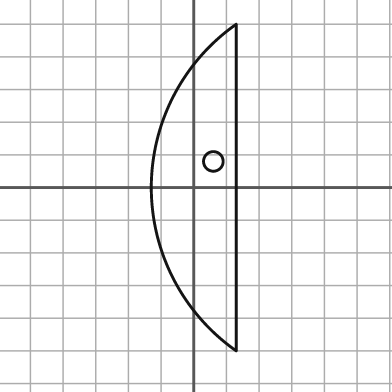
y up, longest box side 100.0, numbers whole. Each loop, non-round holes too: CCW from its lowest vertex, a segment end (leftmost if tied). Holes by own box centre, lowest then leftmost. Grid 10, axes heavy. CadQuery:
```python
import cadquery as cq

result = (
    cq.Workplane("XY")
    .moveTo(13.0, -50.0)
    .lineTo(13.0, 50.0)
    .threePointArc((-13.0, 0.0), (13.0, -50.0))
    .close()
    .moveTo(6.0, 8.0)
    .circle(3.0)
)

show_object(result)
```